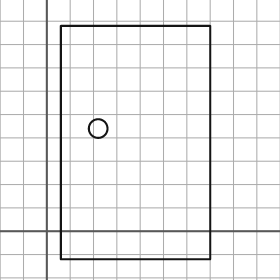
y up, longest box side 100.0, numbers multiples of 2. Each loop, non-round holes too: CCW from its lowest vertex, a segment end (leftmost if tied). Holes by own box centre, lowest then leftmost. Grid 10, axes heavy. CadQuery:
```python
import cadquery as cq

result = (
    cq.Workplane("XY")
    .moveTo(6.0, -12.0)
    .lineTo(70.0, -12.0)
    .lineTo(70.0, 88.0)
    .lineTo(6.0, 88.0)
    .close()
    .moveTo(22.0, 44.0)
    .circle(4.0)
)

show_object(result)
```